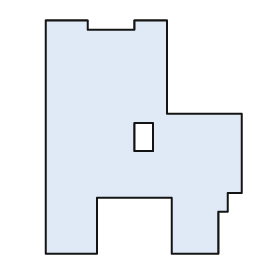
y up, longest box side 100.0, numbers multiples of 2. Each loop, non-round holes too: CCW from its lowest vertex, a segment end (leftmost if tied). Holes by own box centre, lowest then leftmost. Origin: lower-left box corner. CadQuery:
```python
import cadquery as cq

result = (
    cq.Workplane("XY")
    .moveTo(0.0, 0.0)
    .lineTo(22.0, 0.0)
    .lineTo(22.0, 24.0)
    .lineTo(54.0, 24.0)
    .lineTo(54.0, 0.0)
    .lineTo(74.0, 0.0)
    .lineTo(74.0, 18.0)
    .lineTo(78.0, 18.0)
    .lineTo(78.0, 26.0)
    .lineTo(84.0, 26.0)
    .lineTo(84.0, 60.0)
    .lineTo(52.0, 60.0)
    .lineTo(52.0, 100.0)
    .lineTo(38.0, 100.0)
    .lineTo(38.0, 96.0)
    .lineTo(18.0, 96.0)
    .lineTo(18.0, 100.0)
    .lineTo(0.0, 100.0)
    .close()
    .moveTo(38.0, 44.0)
    .lineTo(46.0, 44.0)
    .lineTo(46.0, 56.0)
    .lineTo(38.0, 56.0)
    .close()
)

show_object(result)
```